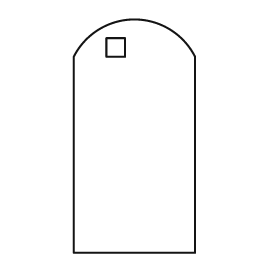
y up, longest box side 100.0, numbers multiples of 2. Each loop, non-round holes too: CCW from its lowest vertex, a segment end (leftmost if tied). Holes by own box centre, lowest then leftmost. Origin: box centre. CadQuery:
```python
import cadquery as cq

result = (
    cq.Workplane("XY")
    .moveTo(-26.0, -50.0)
    .lineTo(26.0, -50.0)
    .lineTo(26.0, 34.0)
    .threePointArc((0.0, 50.0), (-26.0, 34.0))
    .close()
    .moveTo(-12.0, 34.0)
    .lineTo(-4.0, 34.0)
    .lineTo(-4.0, 42.0)
    .lineTo(-12.0, 42.0)
    .close()
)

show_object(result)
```